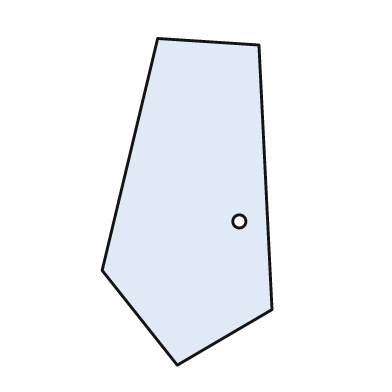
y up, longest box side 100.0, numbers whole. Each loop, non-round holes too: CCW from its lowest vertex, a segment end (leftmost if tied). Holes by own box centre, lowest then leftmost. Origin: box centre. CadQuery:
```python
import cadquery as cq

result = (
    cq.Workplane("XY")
    .moveTo(-3.0, -50.0)
    .lineTo(26.0, -33.0)
    .lineTo(22.0, 48.0)
    .lineTo(-9.0, 50.0)
    .lineTo(-26.0, -21.0)
    .close()
    .moveTo(16.0, -6.0)
    .circle(2.0)
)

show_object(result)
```